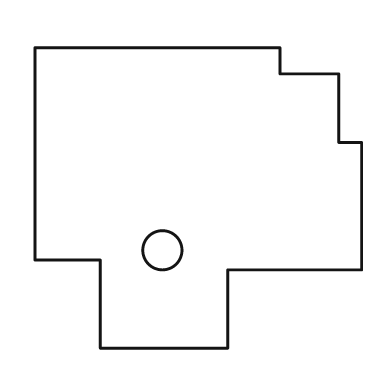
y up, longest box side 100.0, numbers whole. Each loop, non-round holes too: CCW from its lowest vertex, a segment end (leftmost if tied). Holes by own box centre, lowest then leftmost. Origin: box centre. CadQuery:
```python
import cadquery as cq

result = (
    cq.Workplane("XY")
    .moveTo(-30.0, -46.0)
    .lineTo(9.0, -46.0)
    .lineTo(9.0, -22.0)
    .lineTo(50.0, -22.0)
    .lineTo(50.0, 17.0)
    .lineTo(43.0, 17.0)
    .lineTo(43.0, 38.0)
    .lineTo(25.0, 38.0)
    .lineTo(25.0, 46.0)
    .lineTo(-50.0, 46.0)
    .lineTo(-50.0, -19.0)
    .lineTo(-30.0, -19.0)
    .close()
    .moveTo(-11.0, -16.0)
    .circle(6.0)
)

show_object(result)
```